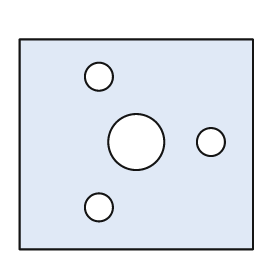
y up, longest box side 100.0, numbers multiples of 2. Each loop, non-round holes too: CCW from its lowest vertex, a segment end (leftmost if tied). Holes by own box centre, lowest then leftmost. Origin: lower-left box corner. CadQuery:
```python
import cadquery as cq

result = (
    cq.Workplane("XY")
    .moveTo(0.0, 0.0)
    .lineTo(100.0, 0.0)
    .lineTo(100.0, 90.0)
    .lineTo(0.0, 90.0)
    .close()
    .moveTo(34.0, 18.0)
    .circle(6.0)
    .moveTo(50.0, 46.0)
    .circle(12.0)
    .moveTo(82.0, 46.0)
    .circle(6.0)
    .moveTo(34.0, 74.0)
    .circle(6.0)
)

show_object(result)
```